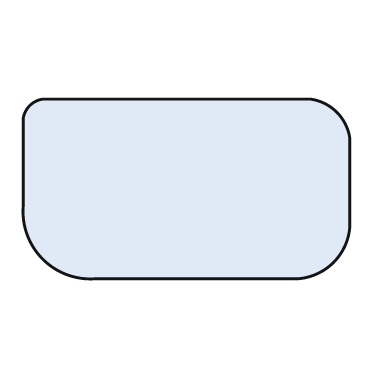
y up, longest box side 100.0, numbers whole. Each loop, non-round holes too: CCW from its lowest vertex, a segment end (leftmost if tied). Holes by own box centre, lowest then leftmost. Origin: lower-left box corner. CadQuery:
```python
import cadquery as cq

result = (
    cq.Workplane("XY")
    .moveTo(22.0, 0.0)
    .lineTo(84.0, 0.0)
    .threePointArc((95.0, 5.0), (100.0, 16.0))
    .lineTo(100.0, 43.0)
    .threePointArc((96.0, 51.0), (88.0, 55.0))
    .lineTo(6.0, 55.0)
    .threePointArc((2.0, 53.0), (0.0, 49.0))
    .lineTo(0.0, 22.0)
    .threePointArc((6.0, 6.0), (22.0, 0.0))
    .close()
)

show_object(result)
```